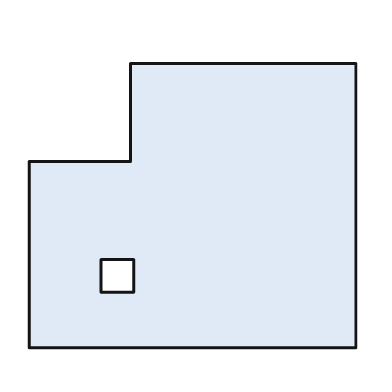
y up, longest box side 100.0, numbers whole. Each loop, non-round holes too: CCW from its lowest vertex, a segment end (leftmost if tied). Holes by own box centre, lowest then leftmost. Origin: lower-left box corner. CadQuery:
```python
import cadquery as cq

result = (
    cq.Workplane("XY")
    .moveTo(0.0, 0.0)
    .lineTo(100.0, 0.0)
    .lineTo(100.0, 87.0)
    .lineTo(31.0, 87.0)
    .lineTo(31.0, 57.0)
    .lineTo(0.0, 57.0)
    .close()
    .moveTo(22.0, 17.0)
    .lineTo(32.0, 17.0)
    .lineTo(32.0, 27.0)
    .lineTo(22.0, 27.0)
    .close()
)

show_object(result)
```